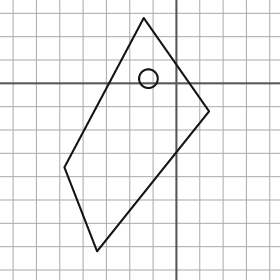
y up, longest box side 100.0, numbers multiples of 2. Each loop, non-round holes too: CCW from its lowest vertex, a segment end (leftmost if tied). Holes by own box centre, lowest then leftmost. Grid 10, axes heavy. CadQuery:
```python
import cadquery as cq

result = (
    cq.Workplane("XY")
    .moveTo(-34.0, -72.0)
    .lineTo(14.0, -12.0)
    .lineTo(-14.0, 28.0)
    .lineTo(-48.0, -36.0)
    .close()
    .moveTo(-12.0, 2.0)
    .circle(4.0)
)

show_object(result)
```